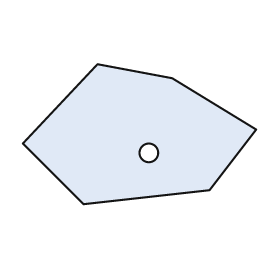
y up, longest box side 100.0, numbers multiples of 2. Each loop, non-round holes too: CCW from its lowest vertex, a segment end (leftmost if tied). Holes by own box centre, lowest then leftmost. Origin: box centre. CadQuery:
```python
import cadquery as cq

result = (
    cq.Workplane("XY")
    .moveTo(-24.0, -30.0)
    .lineTo(30.0, -24.0)
    .lineTo(50.0, 2.0)
    .lineTo(14.0, 24.0)
    .lineTo(-18.0, 30.0)
    .lineTo(-50.0, -4.0)
    .close()
    .moveTo(4.0, -8.0)
    .circle(4.0)
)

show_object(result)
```